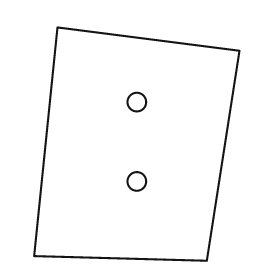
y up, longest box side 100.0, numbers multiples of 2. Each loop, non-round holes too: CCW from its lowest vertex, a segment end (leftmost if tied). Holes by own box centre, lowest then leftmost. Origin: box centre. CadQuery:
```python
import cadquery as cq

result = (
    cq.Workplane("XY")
    .moveTo(30.0, -50.0)
    .lineTo(44.0, 40.0)
    .lineTo(-34.0, 50.0)
    .lineTo(-44.0, -48.0)
    .close()
    .moveTo(0.0, -16.0)
    .circle(4.0)
    .moveTo(0.0, 18.0)
    .circle(4.0)
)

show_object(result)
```